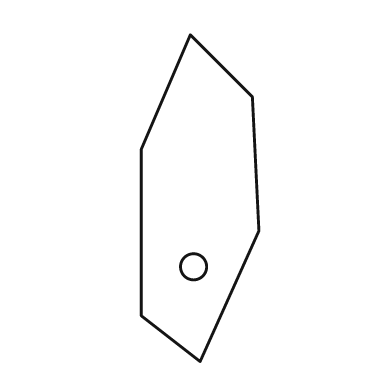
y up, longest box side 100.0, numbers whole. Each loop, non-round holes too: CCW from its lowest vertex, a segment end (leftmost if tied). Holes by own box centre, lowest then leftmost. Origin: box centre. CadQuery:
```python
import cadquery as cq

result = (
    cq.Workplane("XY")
    .moveTo(0.0, -50.0)
    .lineTo(18.0, -10.0)
    .lineTo(16.0, 31.0)
    .lineTo(-3.0, 50.0)
    .lineTo(-18.0, 15.0)
    .lineTo(-18.0, -36.0)
    .close()
    .moveTo(-2.0, -21.0)
    .circle(4.0)
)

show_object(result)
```